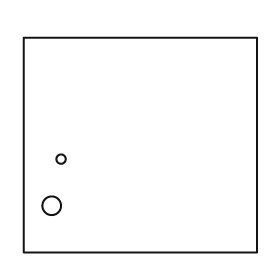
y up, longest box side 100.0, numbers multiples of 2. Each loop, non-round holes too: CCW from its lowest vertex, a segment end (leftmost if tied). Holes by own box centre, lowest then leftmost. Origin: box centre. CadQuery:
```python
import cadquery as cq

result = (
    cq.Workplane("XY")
    .moveTo(-50.0, -46.0)
    .lineTo(50.0, -46.0)
    .lineTo(50.0, 46.0)
    .lineTo(-50.0, 46.0)
    .close()
    .moveTo(-38.0, -26.0)
    .circle(4.0)
    .moveTo(-34.0, -6.0)
    .circle(2.0)
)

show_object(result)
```